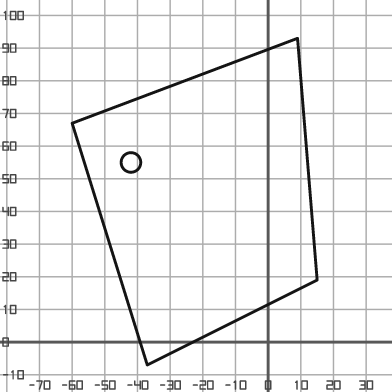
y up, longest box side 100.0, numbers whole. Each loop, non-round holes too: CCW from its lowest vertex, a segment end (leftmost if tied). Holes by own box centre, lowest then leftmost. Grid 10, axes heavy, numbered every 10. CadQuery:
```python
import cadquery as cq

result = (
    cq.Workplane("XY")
    .moveTo(-37.0, -7.0)
    .lineTo(15.0, 19.0)
    .lineTo(9.0, 93.0)
    .lineTo(-60.0, 67.0)
    .close()
    .moveTo(-42.0, 55.0)
    .circle(3.0)
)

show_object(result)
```